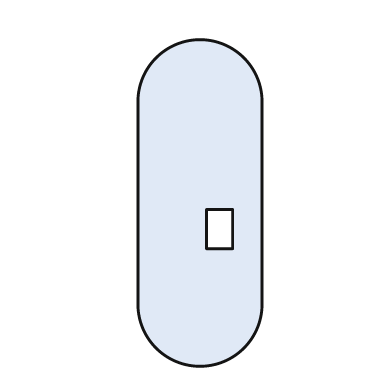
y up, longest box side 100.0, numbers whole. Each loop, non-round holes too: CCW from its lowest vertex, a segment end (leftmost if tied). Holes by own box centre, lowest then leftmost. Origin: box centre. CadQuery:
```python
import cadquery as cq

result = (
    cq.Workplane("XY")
    .moveTo(-19.0, -31.0)
    .threePointArc((0.0, -50.0), (19.0, -31.0))
    .lineTo(19.0, 31.0)
    .threePointArc((0.0, 50.0), (-19.0, 31.0))
    .close()
    .moveTo(2.0, -14.0)
    .lineTo(10.0, -14.0)
    .lineTo(10.0, -2.0)
    .lineTo(2.0, -2.0)
    .close()
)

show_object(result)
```